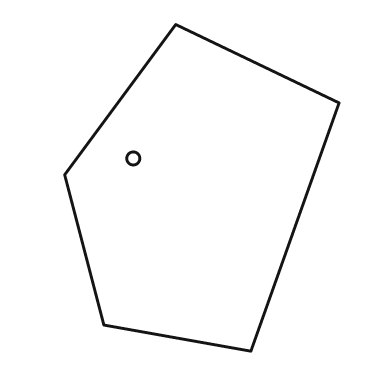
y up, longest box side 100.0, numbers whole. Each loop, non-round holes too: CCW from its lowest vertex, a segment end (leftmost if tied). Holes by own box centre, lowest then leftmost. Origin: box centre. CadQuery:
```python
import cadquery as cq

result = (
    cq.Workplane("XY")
    .moveTo(15.0, -50.0)
    .lineTo(42.0, 26.0)
    .lineTo(-8.0, 50.0)
    .lineTo(-42.0, 4.0)
    .lineTo(-30.0, -42.0)
    .close()
    .moveTo(-21.0, 9.0)
    .circle(2.0)
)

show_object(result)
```